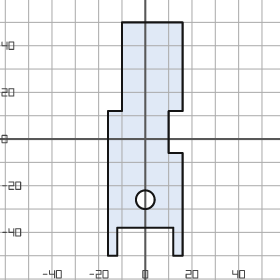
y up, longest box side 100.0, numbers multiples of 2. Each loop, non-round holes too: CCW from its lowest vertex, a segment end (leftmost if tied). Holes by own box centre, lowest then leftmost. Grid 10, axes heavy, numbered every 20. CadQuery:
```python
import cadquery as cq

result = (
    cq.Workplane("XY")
    .moveTo(-16.0, -50.0)
    .lineTo(-12.0, -50.0)
    .lineTo(-12.0, -38.0)
    .lineTo(12.0, -38.0)
    .lineTo(12.0, -50.0)
    .lineTo(16.0, -50.0)
    .lineTo(16.0, -6.0)
    .lineTo(10.0, -6.0)
    .lineTo(10.0, 12.0)
    .lineTo(16.0, 12.0)
    .lineTo(16.0, 50.0)
    .lineTo(-10.0, 50.0)
    .lineTo(-10.0, 12.0)
    .lineTo(-16.0, 12.0)
    .close()
    .moveTo(0.0, -26.0)
    .circle(4.0)
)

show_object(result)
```